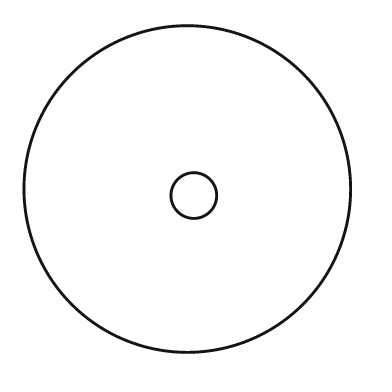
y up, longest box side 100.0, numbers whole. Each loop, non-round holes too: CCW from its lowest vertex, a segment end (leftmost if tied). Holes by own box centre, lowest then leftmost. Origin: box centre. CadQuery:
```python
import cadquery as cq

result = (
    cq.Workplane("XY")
    .moveTo(0.0, 0.0)
    .circle(50.0)
    .moveTo(2.0, -2.0)
    .circle(7.0)
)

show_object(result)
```